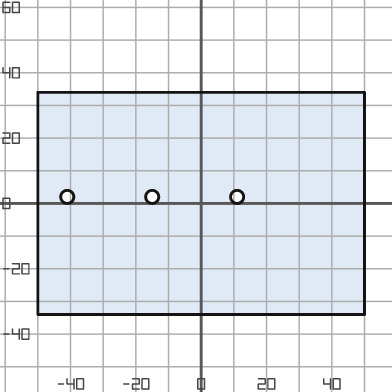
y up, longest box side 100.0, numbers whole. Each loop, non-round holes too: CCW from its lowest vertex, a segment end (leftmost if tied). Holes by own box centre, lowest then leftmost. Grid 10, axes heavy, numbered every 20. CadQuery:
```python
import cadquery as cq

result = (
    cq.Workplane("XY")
    .moveTo(-50.0, -34.0)
    .lineTo(50.0, -34.0)
    .lineTo(50.0, 34.0)
    .lineTo(-50.0, 34.0)
    .close()
    .moveTo(-41.0, 2.0)
    .circle(2.0)
    .moveTo(-15.0, 2.0)
    .circle(2.0)
    .moveTo(11.0, 2.0)
    .circle(2.0)
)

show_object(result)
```